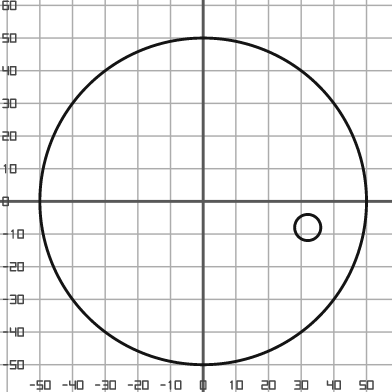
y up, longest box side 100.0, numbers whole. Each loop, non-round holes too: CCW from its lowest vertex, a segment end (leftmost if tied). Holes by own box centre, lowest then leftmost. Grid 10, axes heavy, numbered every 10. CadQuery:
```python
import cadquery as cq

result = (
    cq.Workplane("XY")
    .moveTo(0.0, 0.0)
    .circle(50.0)
    .moveTo(32.0, -8.0)
    .circle(4.0)
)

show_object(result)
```